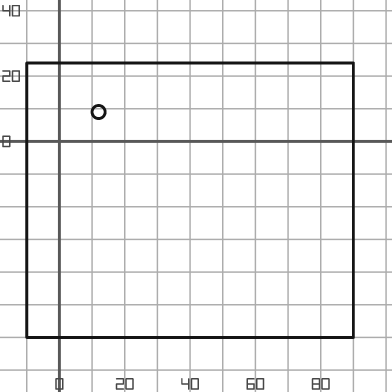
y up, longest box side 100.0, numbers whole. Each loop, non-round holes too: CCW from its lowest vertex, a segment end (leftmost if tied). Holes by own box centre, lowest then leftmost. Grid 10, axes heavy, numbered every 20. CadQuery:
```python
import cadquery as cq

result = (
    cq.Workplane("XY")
    .moveTo(-10.0, -60.0)
    .lineTo(90.0, -60.0)
    .lineTo(90.0, 24.0)
    .lineTo(-10.0, 24.0)
    .close()
    .moveTo(12.0, 9.0)
    .circle(2.0)
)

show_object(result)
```